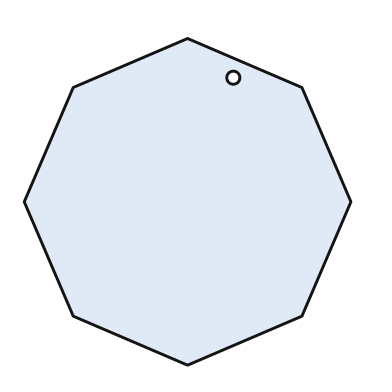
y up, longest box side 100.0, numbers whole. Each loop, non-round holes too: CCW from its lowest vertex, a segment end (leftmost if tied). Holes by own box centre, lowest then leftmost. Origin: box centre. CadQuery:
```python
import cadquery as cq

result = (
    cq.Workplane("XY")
    .moveTo(0.0, -50.0)
    .lineTo(35.0, -35.0)
    .lineTo(50.0, 0.0)
    .lineTo(35.0, 35.0)
    .lineTo(0.0, 50.0)
    .lineTo(-35.0, 35.0)
    .lineTo(-50.0, 0.0)
    .lineTo(-35.0, -35.0)
    .close()
    .moveTo(14.0, 38.0)
    .circle(2.0)
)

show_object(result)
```